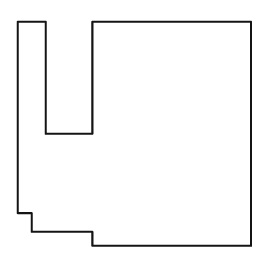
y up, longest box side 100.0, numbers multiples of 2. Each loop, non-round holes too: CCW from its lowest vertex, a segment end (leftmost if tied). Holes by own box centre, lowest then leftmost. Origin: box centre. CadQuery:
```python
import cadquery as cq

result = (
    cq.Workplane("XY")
    .moveTo(-18.0, -48.0)
    .lineTo(50.0, -48.0)
    .lineTo(50.0, 48.0)
    .lineTo(-18.0, 48.0)
    .lineTo(-18.0, 0.0)
    .lineTo(-38.0, 0.0)
    .lineTo(-38.0, 48.0)
    .lineTo(-50.0, 48.0)
    .lineTo(-50.0, -34.0)
    .lineTo(-44.0, -34.0)
    .lineTo(-44.0, -42.0)
    .lineTo(-18.0, -42.0)
    .close()
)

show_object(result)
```